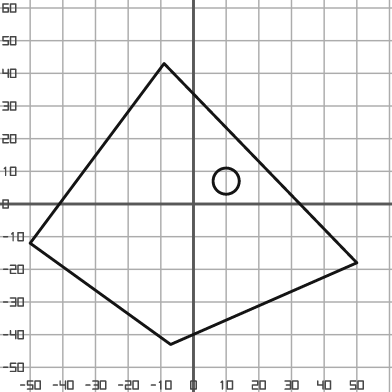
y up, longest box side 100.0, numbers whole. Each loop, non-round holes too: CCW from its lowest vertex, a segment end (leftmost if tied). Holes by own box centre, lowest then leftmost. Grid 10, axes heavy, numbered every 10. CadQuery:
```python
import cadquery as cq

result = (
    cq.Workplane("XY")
    .moveTo(-7.0, -43.0)
    .lineTo(50.0, -18.0)
    .lineTo(-9.0, 43.0)
    .lineTo(-50.0, -12.0)
    .close()
    .moveTo(10.0, 7.0)
    .circle(4.0)
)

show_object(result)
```